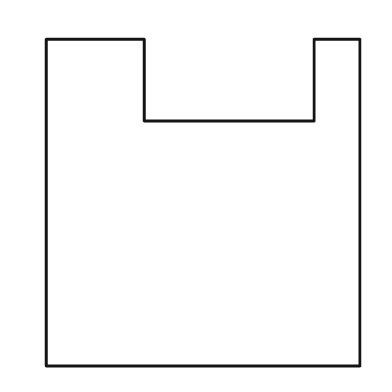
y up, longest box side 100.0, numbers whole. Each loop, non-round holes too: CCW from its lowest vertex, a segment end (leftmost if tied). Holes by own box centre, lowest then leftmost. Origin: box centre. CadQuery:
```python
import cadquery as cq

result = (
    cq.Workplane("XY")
    .moveTo(-48.0, -50.0)
    .lineTo(48.0, -50.0)
    .lineTo(48.0, 50.0)
    .lineTo(34.0, 50.0)
    .lineTo(34.0, 25.0)
    .lineTo(-18.0, 25.0)
    .lineTo(-18.0, 50.0)
    .lineTo(-48.0, 50.0)
    .close()
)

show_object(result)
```